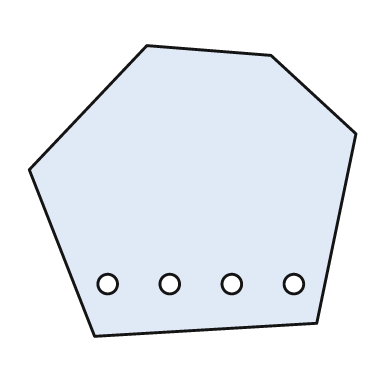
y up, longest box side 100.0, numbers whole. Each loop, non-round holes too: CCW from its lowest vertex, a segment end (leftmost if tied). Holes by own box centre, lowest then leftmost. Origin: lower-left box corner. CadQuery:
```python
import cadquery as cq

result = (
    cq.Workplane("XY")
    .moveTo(20.0, 0.0)
    .lineTo(88.0, 4.0)
    .lineTo(100.0, 62.0)
    .lineTo(74.0, 86.0)
    .lineTo(36.0, 89.0)
    .lineTo(0.0, 51.0)
    .close()
    .moveTo(24.0, 16.0)
    .circle(3.0)
    .moveTo(43.0, 16.0)
    .circle(3.0)
    .moveTo(62.0, 16.0)
    .circle(3.0)
    .moveTo(81.0, 16.0)
    .circle(3.0)
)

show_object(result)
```